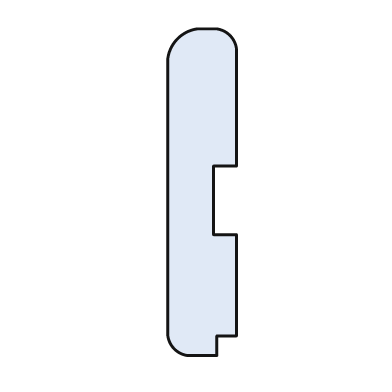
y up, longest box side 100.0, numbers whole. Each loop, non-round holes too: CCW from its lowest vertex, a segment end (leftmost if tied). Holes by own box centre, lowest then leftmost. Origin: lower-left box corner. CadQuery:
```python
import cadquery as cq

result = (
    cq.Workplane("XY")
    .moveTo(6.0, 0.0)
    .lineTo(15.0, 0.0)
    .lineTo(15.0, 6.0)
    .lineTo(21.0, 6.0)
    .lineTo(21.0, 37.0)
    .lineTo(14.0, 37.0)
    .lineTo(14.0, 58.0)
    .lineTo(21.0, 58.0)
    .lineTo(21.0, 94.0)
    .threePointArc((19.0, 98.0), (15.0, 100.0))
    .lineTo(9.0, 100.0)
    .threePointArc((3.0, 97.0), (0.0, 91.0))
    .lineTo(0.0, 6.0)
    .threePointArc((2.0, 2.0), (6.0, 0.0))
    .close()
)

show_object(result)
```